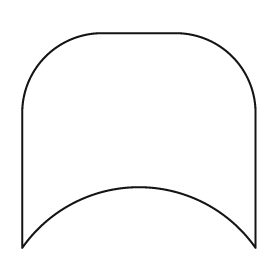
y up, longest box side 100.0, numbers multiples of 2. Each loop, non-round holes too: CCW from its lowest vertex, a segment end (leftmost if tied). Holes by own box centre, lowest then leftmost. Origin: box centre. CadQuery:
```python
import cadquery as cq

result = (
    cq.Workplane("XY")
    .moveTo(-50.0, -46.0)
    .threePointArc((0.0, -20.0), (50.0, -46.0))
    .lineTo(50.0, 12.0)
    .threePointArc((40.0, 36.0), (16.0, 46.0))
    .lineTo(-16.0, 46.0)
    .threePointArc((-40.0, 36.0), (-50.0, 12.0))
    .close()
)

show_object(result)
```